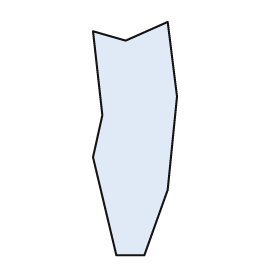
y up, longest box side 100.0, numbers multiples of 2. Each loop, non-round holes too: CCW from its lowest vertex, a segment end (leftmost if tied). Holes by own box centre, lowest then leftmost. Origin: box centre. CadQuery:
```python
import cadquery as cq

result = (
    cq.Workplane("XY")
    .moveTo(-8.0, -50.0)
    .lineTo(4.0, -50.0)
    .lineTo(14.0, -22.0)
    .lineTo(18.0, 18.0)
    .lineTo(14.0, 50.0)
    .lineTo(-4.0, 42.0)
    .lineTo(-18.0, 46.0)
    .lineTo(-14.0, 10.0)
    .lineTo(-18.0, -8.0)
    .close()
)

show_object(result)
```